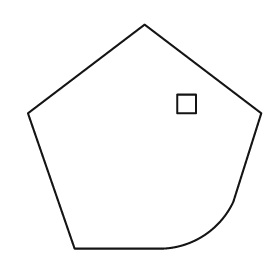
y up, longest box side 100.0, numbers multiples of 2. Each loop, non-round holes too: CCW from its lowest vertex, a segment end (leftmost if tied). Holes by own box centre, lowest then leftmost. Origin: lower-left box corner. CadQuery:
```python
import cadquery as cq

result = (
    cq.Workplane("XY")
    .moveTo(20.0, 0.0)
    .lineTo(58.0, 0.0)
    .threePointArc((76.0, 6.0), (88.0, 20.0))
    .lineTo(100.0, 58.0)
    .lineTo(50.0, 96.0)
    .lineTo(0.0, 58.0)
    .close()
    .moveTo(64.0, 58.0)
    .lineTo(72.0, 58.0)
    .lineTo(72.0, 66.0)
    .lineTo(64.0, 66.0)
    .close()
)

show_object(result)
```